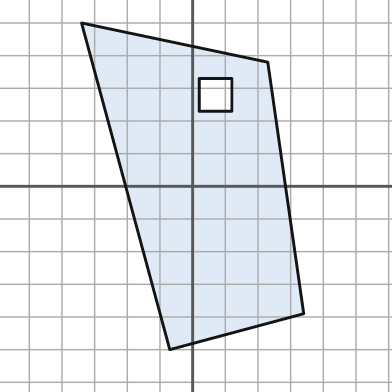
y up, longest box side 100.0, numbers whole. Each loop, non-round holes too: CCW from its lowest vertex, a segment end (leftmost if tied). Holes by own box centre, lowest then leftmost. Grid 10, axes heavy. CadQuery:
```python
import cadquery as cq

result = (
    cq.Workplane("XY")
    .moveTo(-7.0, -50.0)
    .lineTo(34.0, -39.0)
    .lineTo(23.0, 38.0)
    .lineTo(-34.0, 50.0)
    .close()
    .moveTo(2.0, 23.0)
    .lineTo(12.0, 23.0)
    .lineTo(12.0, 33.0)
    .lineTo(2.0, 33.0)
    .close()
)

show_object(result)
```